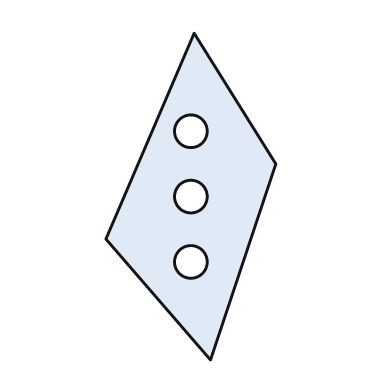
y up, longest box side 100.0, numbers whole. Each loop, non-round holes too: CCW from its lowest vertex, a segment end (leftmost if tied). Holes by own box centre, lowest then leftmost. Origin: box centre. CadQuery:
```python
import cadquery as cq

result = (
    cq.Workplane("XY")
    .moveTo(6.0, -50.0)
    .lineTo(26.0, 10.0)
    .lineTo(1.0, 50.0)
    .lineTo(-26.0, -13.0)
    .close()
    .moveTo(0.0, -20.0)
    .circle(5.0)
    .moveTo(0.0, 0.0)
    .circle(5.0)
    .moveTo(0.0, 20.0)
    .circle(5.0)
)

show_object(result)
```